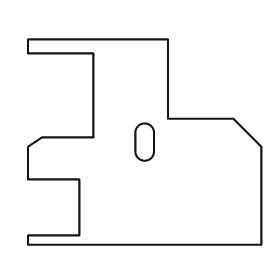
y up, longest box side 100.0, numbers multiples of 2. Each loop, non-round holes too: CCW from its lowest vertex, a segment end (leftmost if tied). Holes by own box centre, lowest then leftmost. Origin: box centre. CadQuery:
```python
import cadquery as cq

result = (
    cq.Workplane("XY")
    .moveTo(-50.0, -44.0)
    .lineTo(50.0, -44.0)
    .lineTo(50.0, -2.0)
    .lineTo(38.0, 10.0)
    .lineTo(10.0, 10.0)
    .lineTo(10.0, 44.0)
    .lineTo(-50.0, 44.0)
    .lineTo(-50.0, 38.0)
    .lineTo(-22.0, 38.0)
    .lineTo(-22.0, 2.0)
    .lineTo(-44.0, 2.0)
    .lineTo(-50.0, -2.0)
    .lineTo(-50.0, -16.0)
    .lineTo(-28.0, -16.0)
    .lineTo(-28.0, -40.0)
    .lineTo(-50.0, -40.0)
    .close()
    .moveTo(-4.0, -4.0)
    .threePointArc((0.0, -8.0), (4.0, -4.0))
    .lineTo(4.0, 4.0)
    .threePointArc((0.0, 8.0), (-4.0, 4.0))
    .close()
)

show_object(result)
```